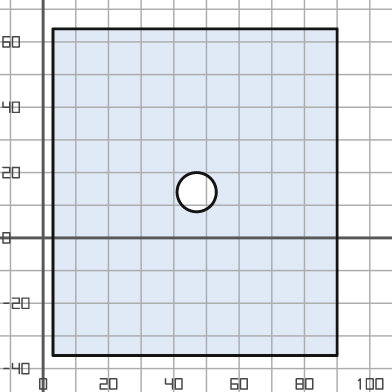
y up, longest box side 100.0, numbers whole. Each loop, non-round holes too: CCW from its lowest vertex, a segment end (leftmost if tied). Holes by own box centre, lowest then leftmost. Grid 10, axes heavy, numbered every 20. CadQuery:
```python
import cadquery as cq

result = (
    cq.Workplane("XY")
    .moveTo(3.0, -36.0)
    .lineTo(90.0, -36.0)
    .lineTo(90.0, 64.0)
    .lineTo(3.0, 64.0)
    .close()
    .moveTo(47.0, 14.0)
    .circle(6.0)
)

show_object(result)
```